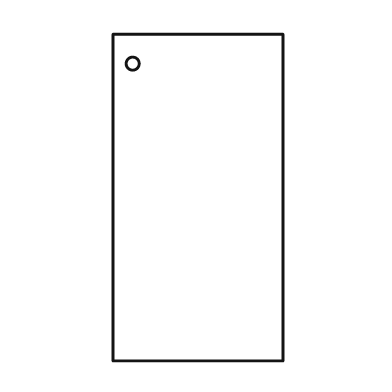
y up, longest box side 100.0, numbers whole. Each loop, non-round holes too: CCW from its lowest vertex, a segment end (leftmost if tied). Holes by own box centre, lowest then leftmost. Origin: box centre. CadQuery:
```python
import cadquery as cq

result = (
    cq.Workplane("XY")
    .moveTo(-26.0, -50.0)
    .lineTo(26.0, -50.0)
    .lineTo(26.0, 50.0)
    .lineTo(-26.0, 50.0)
    .close()
    .moveTo(-20.0, 41.0)
    .circle(2.0)
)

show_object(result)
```